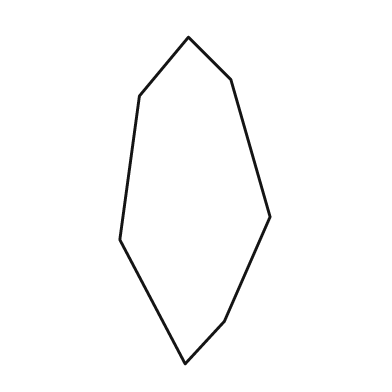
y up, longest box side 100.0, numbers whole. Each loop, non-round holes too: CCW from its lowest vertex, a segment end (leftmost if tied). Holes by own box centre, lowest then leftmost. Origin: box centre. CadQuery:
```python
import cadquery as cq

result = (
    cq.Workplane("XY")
    .moveTo(-3.0, -50.0)
    .lineTo(9.0, -37.0)
    .lineTo(23.0, -5.0)
    .lineTo(11.0, 37.0)
    .lineTo(-2.0, 50.0)
    .lineTo(-17.0, 32.0)
    .lineTo(-23.0, -12.0)
    .close()
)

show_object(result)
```